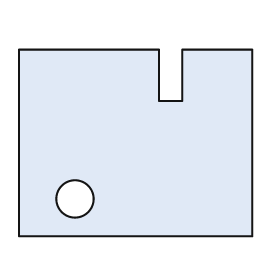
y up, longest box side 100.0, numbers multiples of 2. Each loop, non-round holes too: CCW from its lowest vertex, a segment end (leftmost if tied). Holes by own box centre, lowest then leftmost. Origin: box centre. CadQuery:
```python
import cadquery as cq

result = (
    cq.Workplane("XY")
    .moveTo(-50.0, -40.0)
    .lineTo(50.0, -40.0)
    .lineTo(50.0, 40.0)
    .lineTo(20.0, 40.0)
    .lineTo(20.0, 18.0)
    .lineTo(10.0, 18.0)
    .lineTo(10.0, 40.0)
    .lineTo(-50.0, 40.0)
    .close()
    .moveTo(-26.0, -24.0)
    .circle(8.0)
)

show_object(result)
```